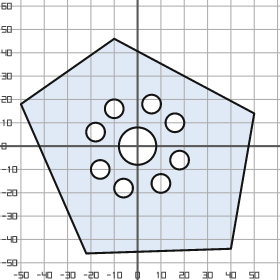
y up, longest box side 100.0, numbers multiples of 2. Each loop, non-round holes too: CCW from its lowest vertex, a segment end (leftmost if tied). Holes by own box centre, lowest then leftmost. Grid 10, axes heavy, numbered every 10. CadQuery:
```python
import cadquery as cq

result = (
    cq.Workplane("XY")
    .moveTo(-22.0, -46.0)
    .lineTo(40.0, -44.0)
    .lineTo(50.0, 14.0)
    .lineTo(-10.0, 46.0)
    .lineTo(-50.0, 18.0)
    .close()
    .moveTo(-6.0, -18.0)
    .circle(4.0)
    .moveTo(10.0, -16.0)
    .circle(4.0)
    .moveTo(-16.0, -10.0)
    .circle(4.0)
    .moveTo(18.0, -6.0)
    .circle(4.0)
    .moveTo(0.0, 0.0)
    .circle(8.0)
    .moveTo(-18.0, 6.0)
    .circle(4.0)
    .moveTo(16.0, 10.0)
    .circle(4.0)
    .moveTo(-10.0, 16.0)
    .circle(4.0)
    .moveTo(6.0, 18.0)
    .circle(4.0)
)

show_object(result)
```